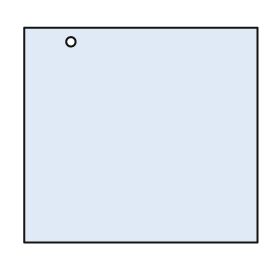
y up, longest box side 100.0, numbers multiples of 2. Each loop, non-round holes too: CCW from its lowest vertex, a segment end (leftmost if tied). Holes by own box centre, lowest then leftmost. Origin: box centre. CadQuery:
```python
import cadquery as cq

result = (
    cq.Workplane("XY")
    .moveTo(-50.0, -46.0)
    .lineTo(50.0, -46.0)
    .lineTo(50.0, 46.0)
    .lineTo(-50.0, 46.0)
    .close()
    .moveTo(-30.0, 40.0)
    .circle(2.0)
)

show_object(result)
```